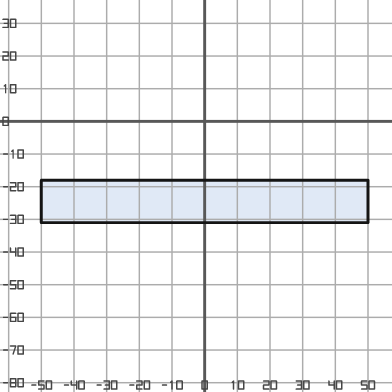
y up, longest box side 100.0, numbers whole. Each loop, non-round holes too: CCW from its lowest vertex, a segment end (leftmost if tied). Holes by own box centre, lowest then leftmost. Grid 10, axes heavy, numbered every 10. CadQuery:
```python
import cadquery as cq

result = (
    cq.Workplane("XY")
    .moveTo(-50.0, -31.0)
    .lineTo(50.0, -31.0)
    .lineTo(50.0, -18.0)
    .lineTo(-50.0, -18.0)
    .close()
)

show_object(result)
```